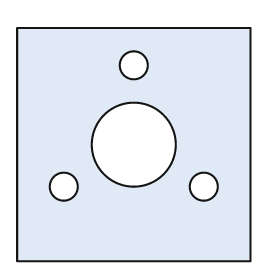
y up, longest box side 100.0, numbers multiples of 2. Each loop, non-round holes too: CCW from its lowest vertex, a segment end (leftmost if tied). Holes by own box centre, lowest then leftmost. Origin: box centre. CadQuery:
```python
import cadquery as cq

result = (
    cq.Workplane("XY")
    .moveTo(-50.0, -50.0)
    .lineTo(50.0, -50.0)
    .lineTo(50.0, 50.0)
    .lineTo(-50.0, 50.0)
    .close()
    .moveTo(-30.0, -18.0)
    .circle(6.0)
    .moveTo(30.0, -18.0)
    .circle(6.0)
    .moveTo(0.0, 0.0)
    .circle(18.0)
    .moveTo(0.0, 34.0)
    .circle(6.0)
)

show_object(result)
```